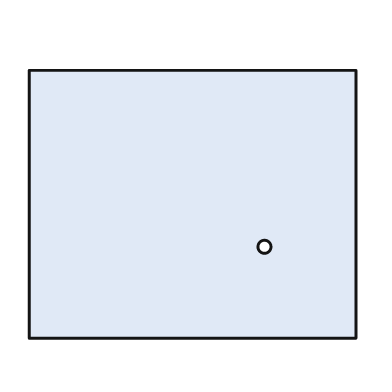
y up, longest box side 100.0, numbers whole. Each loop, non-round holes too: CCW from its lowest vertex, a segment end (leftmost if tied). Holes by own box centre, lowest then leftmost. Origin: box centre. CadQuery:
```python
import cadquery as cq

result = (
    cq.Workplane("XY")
    .moveTo(-50.0, -41.0)
    .lineTo(50.0, -41.0)
    .lineTo(50.0, 41.0)
    .lineTo(-50.0, 41.0)
    .close()
    .moveTo(22.0, -13.0)
    .circle(2.0)
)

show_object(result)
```